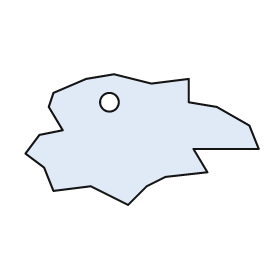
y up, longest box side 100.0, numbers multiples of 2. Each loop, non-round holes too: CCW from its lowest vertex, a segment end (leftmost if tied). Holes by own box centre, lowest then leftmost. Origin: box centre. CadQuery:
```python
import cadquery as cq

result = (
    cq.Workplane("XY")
    .moveTo(-6.0, -28.0)
    .lineTo(2.0, -20.0)
    .lineTo(10.0, -16.0)
    .lineTo(28.0, -14.0)
    .lineTo(22.0, -4.0)
    .lineTo(50.0, -4.0)
    .lineTo(46.0, 6.0)
    .lineTo(32.0, 14.0)
    .lineTo(20.0, 16.0)
    .lineTo(20.0, 26.0)
    .lineTo(4.0, 24.0)
    .lineTo(-12.0, 28.0)
    .lineTo(-24.0, 26.0)
    .lineTo(-38.0, 20.0)
    .lineTo(-40.0, 14.0)
    .lineTo(-34.0, 4.0)
    .lineTo(-44.0, 2.0)
    .lineTo(-50.0, -6.0)
    .lineTo(-42.0, -12.0)
    .lineTo(-38.0, -22.0)
    .lineTo(-22.0, -20.0)
    .close()
    .moveTo(-14.0, 16.0)
    .circle(4.0)
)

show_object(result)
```